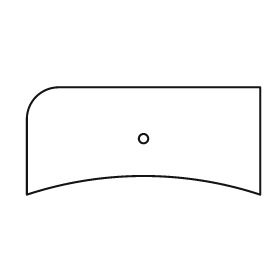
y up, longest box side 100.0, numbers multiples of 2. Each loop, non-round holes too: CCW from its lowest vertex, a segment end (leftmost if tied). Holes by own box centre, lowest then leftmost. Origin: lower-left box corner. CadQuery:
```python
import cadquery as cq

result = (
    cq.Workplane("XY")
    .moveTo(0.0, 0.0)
    .threePointArc((50.0, 8.0), (100.0, 0.0))
    .lineTo(100.0, 46.0)
    .lineTo(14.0, 46.0)
    .threePointArc((4.0, 42.0), (0.0, 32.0))
    .close()
    .moveTo(50.0, 24.0)
    .circle(2.0)
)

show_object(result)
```